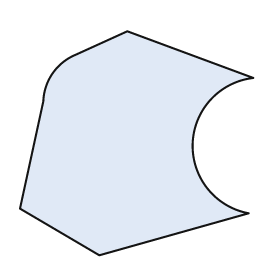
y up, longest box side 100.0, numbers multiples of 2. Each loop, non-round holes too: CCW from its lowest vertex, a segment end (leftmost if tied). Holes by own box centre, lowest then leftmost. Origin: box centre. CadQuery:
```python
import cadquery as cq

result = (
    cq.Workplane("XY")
    .moveTo(-16.0, -48.0)
    .lineTo(48.0, -30.0)
    .threePointArc((24.0, 0.0), (50.0, 28.0))
    .lineTo(-4.0, 48.0)
    .lineTo(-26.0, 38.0)
    .threePointArc((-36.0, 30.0), (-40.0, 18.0))
    .lineTo(-50.0, -28.0)
    .close()
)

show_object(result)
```